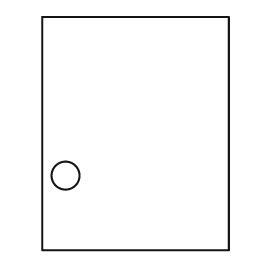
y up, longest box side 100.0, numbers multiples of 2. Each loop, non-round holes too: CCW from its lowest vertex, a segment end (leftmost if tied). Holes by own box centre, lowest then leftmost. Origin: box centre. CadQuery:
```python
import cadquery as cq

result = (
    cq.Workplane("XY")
    .moveTo(-40.0, -50.0)
    .lineTo(40.0, -50.0)
    .lineTo(40.0, 50.0)
    .lineTo(-40.0, 50.0)
    .close()
    .moveTo(-30.0, -18.0)
    .circle(6.0)
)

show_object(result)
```